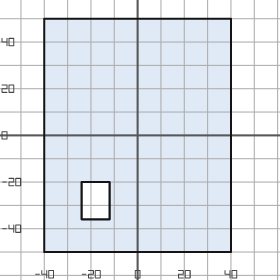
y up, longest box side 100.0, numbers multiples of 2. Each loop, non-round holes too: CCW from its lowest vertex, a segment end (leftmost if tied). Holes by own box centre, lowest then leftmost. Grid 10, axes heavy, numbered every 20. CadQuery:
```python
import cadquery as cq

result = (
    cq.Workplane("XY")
    .moveTo(-40.0, -50.0)
    .lineTo(40.0, -50.0)
    .lineTo(40.0, 50.0)
    .lineTo(-40.0, 50.0)
    .close()
    .moveTo(-24.0, -36.0)
    .lineTo(-12.0, -36.0)
    .lineTo(-12.0, -20.0)
    .lineTo(-24.0, -20.0)
    .close()
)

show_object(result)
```